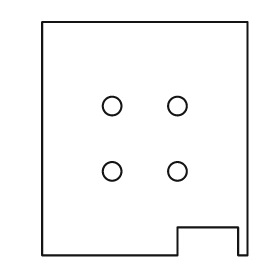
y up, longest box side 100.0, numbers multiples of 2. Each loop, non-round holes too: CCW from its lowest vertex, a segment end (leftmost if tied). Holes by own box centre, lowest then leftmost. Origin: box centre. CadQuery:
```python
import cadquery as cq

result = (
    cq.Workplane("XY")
    .moveTo(-44.0, -50.0)
    .lineTo(14.0, -50.0)
    .lineTo(14.0, -38.0)
    .lineTo(40.0, -38.0)
    .lineTo(40.0, -50.0)
    .lineTo(44.0, -50.0)
    .lineTo(44.0, 50.0)
    .lineTo(-44.0, 50.0)
    .close()
    .moveTo(-14.0, -14.0)
    .circle(4.0)
    .moveTo(14.0, -14.0)
    .circle(4.0)
    .moveTo(-14.0, 14.0)
    .circle(4.0)
    .moveTo(14.0, 14.0)
    .circle(4.0)
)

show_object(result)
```